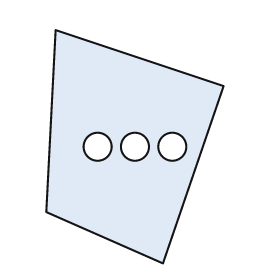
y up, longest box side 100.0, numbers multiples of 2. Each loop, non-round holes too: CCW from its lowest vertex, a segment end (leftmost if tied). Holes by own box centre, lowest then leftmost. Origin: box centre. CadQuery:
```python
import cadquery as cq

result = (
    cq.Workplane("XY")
    .moveTo(12.0, -50.0)
    .lineTo(38.0, 26.0)
    .lineTo(-34.0, 50.0)
    .lineTo(-38.0, -28.0)
    .close()
    .moveTo(-16.0, 0.0)
    .circle(6.0)
    .moveTo(0.0, 0.0)
    .circle(6.0)
    .moveTo(16.0, 0.0)
    .circle(6.0)
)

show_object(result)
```